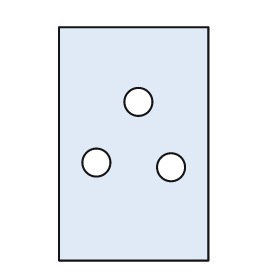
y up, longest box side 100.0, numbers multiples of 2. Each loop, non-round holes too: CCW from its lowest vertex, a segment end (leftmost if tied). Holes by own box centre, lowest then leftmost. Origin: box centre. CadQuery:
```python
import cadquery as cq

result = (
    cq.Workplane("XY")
    .moveTo(-32.0, -50.0)
    .lineTo(32.0, -50.0)
    .lineTo(32.0, 50.0)
    .lineTo(-32.0, 50.0)
    .close()
    .moveTo(16.0, -10.0)
    .circle(6.0)
    .moveTo(-16.0, -8.0)
    .circle(6.0)
    .moveTo(2.0, 18.0)
    .circle(6.0)
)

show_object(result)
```